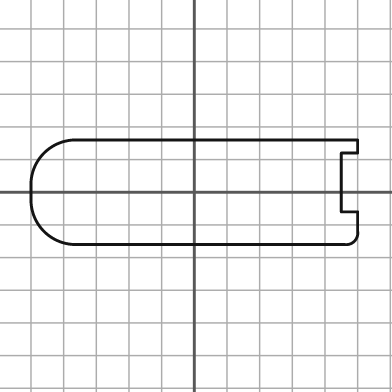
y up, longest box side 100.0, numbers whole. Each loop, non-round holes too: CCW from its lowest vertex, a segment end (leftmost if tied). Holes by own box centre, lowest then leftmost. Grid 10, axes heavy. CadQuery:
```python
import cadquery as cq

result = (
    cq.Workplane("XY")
    .moveTo(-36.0, -16.0)
    .lineTo(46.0, -16.0)
    .threePointArc((49.0, -15.0), (50.0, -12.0))
    .lineTo(50.0, -6.0)
    .lineTo(45.0, -6.0)
    .lineTo(45.0, 12.0)
    .lineTo(50.0, 12.0)
    .lineTo(50.0, 16.0)
    .lineTo(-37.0, 16.0)
    .threePointArc((-46.0, 12.0), (-50.0, 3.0))
    .lineTo(-50.0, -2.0)
    .threePointArc((-46.0, -12.0), (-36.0, -16.0))
    .close()
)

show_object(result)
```